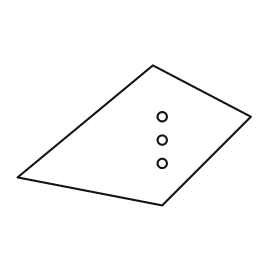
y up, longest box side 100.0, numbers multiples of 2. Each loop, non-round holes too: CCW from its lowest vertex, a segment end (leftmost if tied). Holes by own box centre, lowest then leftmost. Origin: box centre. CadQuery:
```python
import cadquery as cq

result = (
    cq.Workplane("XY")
    .moveTo(12.0, -30.0)
    .lineTo(50.0, 8.0)
    .lineTo(8.0, 30.0)
    .lineTo(-50.0, -18.0)
    .close()
    .moveTo(12.0, -12.0)
    .circle(2.0)
    .moveTo(12.0, -2.0)
    .circle(2.0)
    .moveTo(12.0, 8.0)
    .circle(2.0)
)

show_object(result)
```